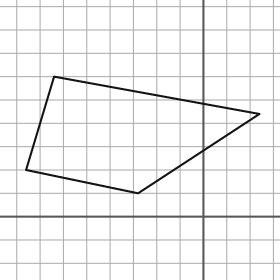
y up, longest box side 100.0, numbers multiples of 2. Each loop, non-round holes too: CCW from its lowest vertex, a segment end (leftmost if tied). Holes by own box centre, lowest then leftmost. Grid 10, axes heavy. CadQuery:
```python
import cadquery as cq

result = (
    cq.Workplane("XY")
    .moveTo(-28.0, 10.0)
    .lineTo(24.0, 44.0)
    .lineTo(-64.0, 60.0)
    .lineTo(-76.0, 20.0)
    .close()
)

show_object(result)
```